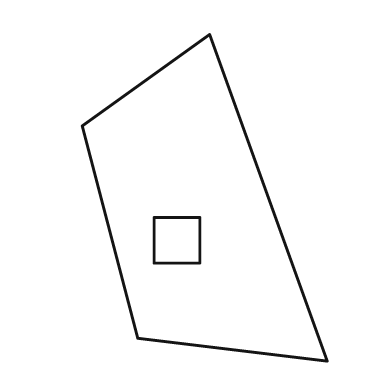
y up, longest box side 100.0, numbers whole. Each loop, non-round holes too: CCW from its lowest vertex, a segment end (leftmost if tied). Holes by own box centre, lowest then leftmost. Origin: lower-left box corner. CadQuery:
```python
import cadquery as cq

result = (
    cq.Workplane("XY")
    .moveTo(75.0, 0.0)
    .lineTo(39.0, 100.0)
    .lineTo(0.0, 72.0)
    .lineTo(17.0, 7.0)
    .close()
    .moveTo(22.0, 30.0)
    .lineTo(36.0, 30.0)
    .lineTo(36.0, 44.0)
    .lineTo(22.0, 44.0)
    .close()
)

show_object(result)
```